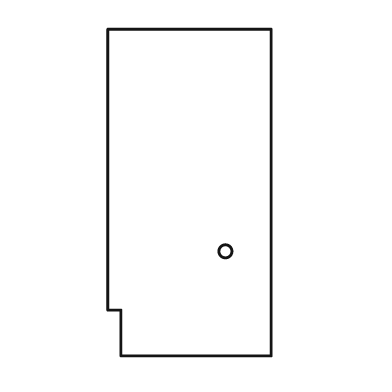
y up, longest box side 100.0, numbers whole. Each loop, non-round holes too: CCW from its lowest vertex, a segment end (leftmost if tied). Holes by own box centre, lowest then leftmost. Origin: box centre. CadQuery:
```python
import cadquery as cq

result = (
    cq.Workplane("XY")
    .moveTo(-21.0, -50.0)
    .lineTo(25.0, -50.0)
    .lineTo(25.0, 50.0)
    .lineTo(-25.0, 50.0)
    .lineTo(-25.0, -36.0)
    .lineTo(-21.0, -36.0)
    .close()
    .moveTo(11.0, -18.0)
    .circle(2.0)
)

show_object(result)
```